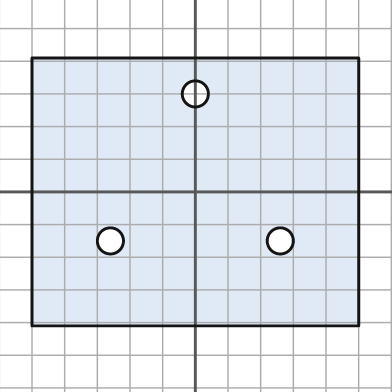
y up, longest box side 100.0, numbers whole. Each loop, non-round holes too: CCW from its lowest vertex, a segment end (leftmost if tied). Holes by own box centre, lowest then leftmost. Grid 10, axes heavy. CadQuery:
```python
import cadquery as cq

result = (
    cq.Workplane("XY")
    .moveTo(-50.0, -41.0)
    .lineTo(50.0, -41.0)
    .lineTo(50.0, 41.0)
    .lineTo(-50.0, 41.0)
    .close()
    .moveTo(-26.0, -15.0)
    .circle(4.0)
    .moveTo(26.0, -15.0)
    .circle(4.0)
    .moveTo(0.0, 30.0)
    .circle(4.0)
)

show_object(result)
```